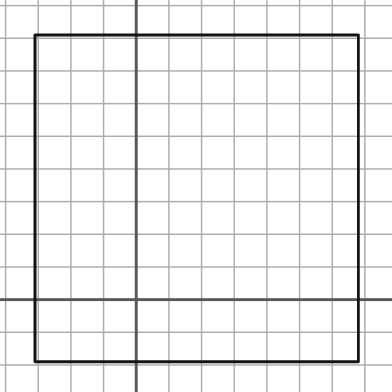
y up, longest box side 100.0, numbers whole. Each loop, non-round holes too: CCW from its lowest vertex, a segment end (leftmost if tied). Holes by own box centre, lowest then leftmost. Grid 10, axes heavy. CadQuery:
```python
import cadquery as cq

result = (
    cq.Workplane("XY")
    .moveTo(-31.0, -19.0)
    .lineTo(68.0, -19.0)
    .lineTo(68.0, 81.0)
    .lineTo(-31.0, 81.0)
    .close()
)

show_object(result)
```